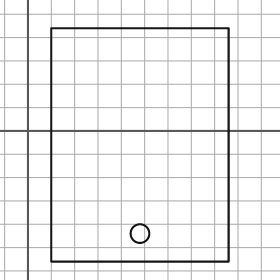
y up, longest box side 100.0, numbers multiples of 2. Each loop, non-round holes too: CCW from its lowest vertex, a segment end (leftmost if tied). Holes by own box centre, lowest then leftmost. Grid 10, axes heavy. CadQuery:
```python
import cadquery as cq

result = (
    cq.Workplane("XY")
    .moveTo(10.0, -56.0)
    .lineTo(86.0, -56.0)
    .lineTo(86.0, 44.0)
    .lineTo(10.0, 44.0)
    .close()
    .moveTo(48.0, -44.0)
    .circle(4.0)
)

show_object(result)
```